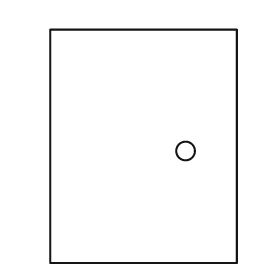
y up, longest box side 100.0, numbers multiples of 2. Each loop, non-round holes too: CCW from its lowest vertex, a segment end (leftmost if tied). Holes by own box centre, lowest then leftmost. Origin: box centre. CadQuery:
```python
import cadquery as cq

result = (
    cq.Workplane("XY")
    .moveTo(-40.0, -50.0)
    .lineTo(40.0, -50.0)
    .lineTo(40.0, 50.0)
    .lineTo(-40.0, 50.0)
    .close()
    .moveTo(18.0, -2.0)
    .circle(4.0)
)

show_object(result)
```